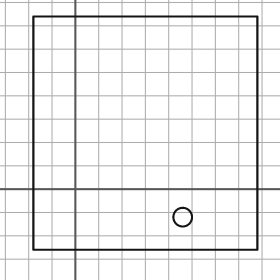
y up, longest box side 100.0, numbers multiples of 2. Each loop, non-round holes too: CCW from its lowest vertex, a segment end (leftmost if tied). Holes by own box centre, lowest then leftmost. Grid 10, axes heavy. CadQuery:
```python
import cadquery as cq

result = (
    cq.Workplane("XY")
    .moveTo(-18.0, -26.0)
    .lineTo(78.0, -26.0)
    .lineTo(78.0, 74.0)
    .lineTo(-18.0, 74.0)
    .close()
    .moveTo(46.0, -12.0)
    .circle(4.0)
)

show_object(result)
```